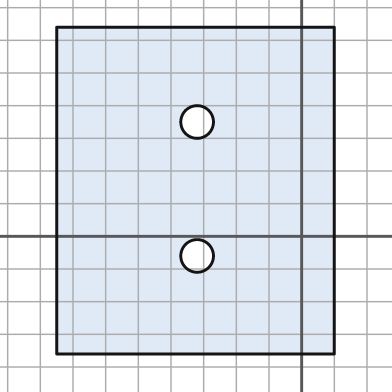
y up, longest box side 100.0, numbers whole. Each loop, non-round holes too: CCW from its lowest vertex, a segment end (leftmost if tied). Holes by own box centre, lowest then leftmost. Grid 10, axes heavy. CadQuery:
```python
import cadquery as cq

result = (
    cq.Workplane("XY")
    .moveTo(-75.0, -36.0)
    .lineTo(10.0, -36.0)
    .lineTo(10.0, 64.0)
    .lineTo(-75.0, 64.0)
    .close()
    .moveTo(-32.0, -6.0)
    .circle(5.0)
    .moveTo(-32.0, 35.0)
    .circle(5.0)
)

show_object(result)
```